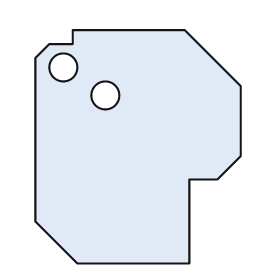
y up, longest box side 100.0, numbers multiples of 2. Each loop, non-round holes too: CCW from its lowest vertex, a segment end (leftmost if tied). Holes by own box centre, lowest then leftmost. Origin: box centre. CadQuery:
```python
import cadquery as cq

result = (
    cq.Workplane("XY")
    .moveTo(-26.0, -50.0)
    .lineTo(22.0, -50.0)
    .lineTo(22.0, -14.0)
    .lineTo(34.0, -14.0)
    .lineTo(44.0, -4.0)
    .lineTo(44.0, 26.0)
    .lineTo(20.0, 50.0)
    .lineTo(-28.0, 50.0)
    .lineTo(-28.0, 44.0)
    .lineTo(-38.0, 44.0)
    .lineTo(-44.0, 38.0)
    .lineTo(-44.0, -32.0)
    .close()
    .moveTo(-14.0, 22.0)
    .circle(6.0)
    .moveTo(-32.0, 34.0)
    .circle(6.0)
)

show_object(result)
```